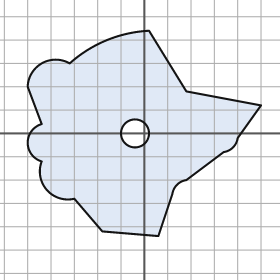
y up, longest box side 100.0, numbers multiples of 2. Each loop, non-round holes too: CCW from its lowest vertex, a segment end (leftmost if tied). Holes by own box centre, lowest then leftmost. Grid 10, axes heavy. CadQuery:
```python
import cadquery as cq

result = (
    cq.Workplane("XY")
    .moveTo(6.0, -44.0)
    .lineTo(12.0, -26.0)
    .threePointArc((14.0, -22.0), (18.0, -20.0))
    .lineTo(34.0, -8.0)
    .threePointArc((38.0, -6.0), (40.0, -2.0))
    .lineTo(50.0, 12.0)
    .lineTo(18.0, 18.0)
    .lineTo(2.0, 44.0)
    .threePointArc((-16.0, 40.0), (-32.0, 30.0))
    .threePointArc((-44.0, 30.0), (-50.0, 20.0))
    .lineTo(-44.0, 4.0)
    .threePointArc((-50.0, -4.0), (-44.0, -12.0))
    .threePointArc((-42.0, -24.0), (-30.0, -28.0))
    .lineTo(-18.0, -42.0)
    .close()
    .moveTo(-4.0, 0.0)
    .circle(6.0)
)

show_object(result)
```